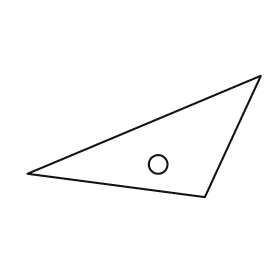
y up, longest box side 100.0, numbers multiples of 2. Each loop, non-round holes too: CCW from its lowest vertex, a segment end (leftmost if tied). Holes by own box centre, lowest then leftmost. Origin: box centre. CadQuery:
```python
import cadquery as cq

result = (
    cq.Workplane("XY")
    .moveTo(26.0, -26.0)
    .lineTo(50.0, 26.0)
    .lineTo(-50.0, -16.0)
    .close()
    .moveTo(6.0, -12.0)
    .circle(4.0)
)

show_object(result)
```